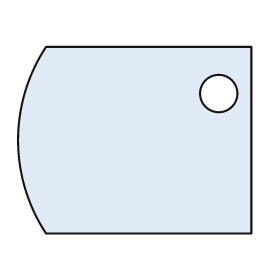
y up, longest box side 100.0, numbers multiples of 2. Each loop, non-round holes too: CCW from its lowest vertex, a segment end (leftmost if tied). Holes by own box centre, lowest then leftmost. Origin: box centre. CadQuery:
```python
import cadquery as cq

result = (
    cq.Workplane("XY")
    .moveTo(-38.0, -40.0)
    .lineTo(50.0, -40.0)
    .lineTo(50.0, 40.0)
    .lineTo(-38.0, 40.0)
    .threePointArc((-50.0, 0.0), (-38.0, -40.0))
    .close()
    .moveTo(36.0, 20.0)
    .circle(8.0)
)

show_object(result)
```